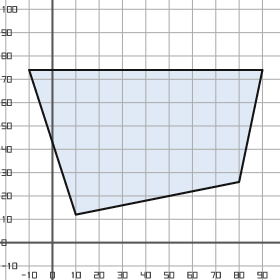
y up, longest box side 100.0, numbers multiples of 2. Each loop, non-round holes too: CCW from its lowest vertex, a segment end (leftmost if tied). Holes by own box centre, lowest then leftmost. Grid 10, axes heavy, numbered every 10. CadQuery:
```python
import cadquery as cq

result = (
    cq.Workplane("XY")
    .moveTo(10.0, 12.0)
    .lineTo(80.0, 26.0)
    .lineTo(90.0, 74.0)
    .lineTo(-10.0, 74.0)
    .close()
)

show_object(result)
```